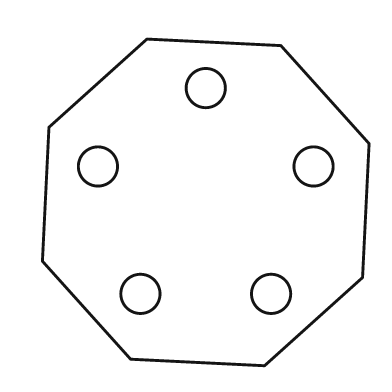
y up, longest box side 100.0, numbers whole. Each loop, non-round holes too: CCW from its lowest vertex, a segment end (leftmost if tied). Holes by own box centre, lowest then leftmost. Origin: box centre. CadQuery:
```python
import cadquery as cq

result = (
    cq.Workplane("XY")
    .moveTo(18.0, -50.0)
    .lineTo(48.0, -23.0)
    .lineTo(50.0, 18.0)
    .lineTo(23.0, 48.0)
    .lineTo(-18.0, 50.0)
    .lineTo(-48.0, 23.0)
    .lineTo(-50.0, -18.0)
    .lineTo(-23.0, -48.0)
    .close()
    .moveTo(-20.0, -28.0)
    .circle(6.0)
    .moveTo(20.0, -28.0)
    .circle(6.0)
    .moveTo(-33.0, 11.0)
    .circle(6.0)
    .moveTo(33.0, 11.0)
    .circle(6.0)
    .moveTo(0.0, 35.0)
    .circle(6.0)
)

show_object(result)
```